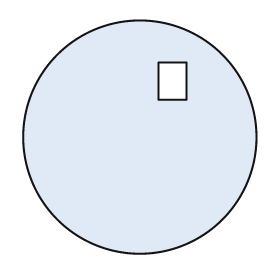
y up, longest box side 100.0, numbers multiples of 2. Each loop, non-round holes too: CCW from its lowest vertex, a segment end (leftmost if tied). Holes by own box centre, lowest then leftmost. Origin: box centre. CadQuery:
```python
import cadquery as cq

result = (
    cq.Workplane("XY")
    .moveTo(0.0, 0.0)
    .circle(50.0)
    .moveTo(8.0, 16.0)
    .lineTo(20.0, 16.0)
    .lineTo(20.0, 32.0)
    .lineTo(8.0, 32.0)
    .close()
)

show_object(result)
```